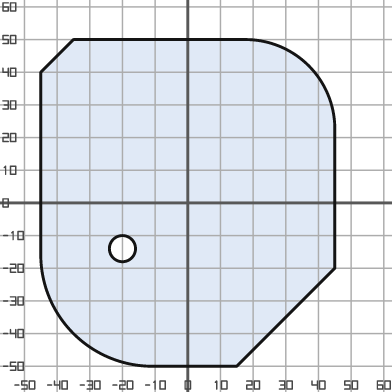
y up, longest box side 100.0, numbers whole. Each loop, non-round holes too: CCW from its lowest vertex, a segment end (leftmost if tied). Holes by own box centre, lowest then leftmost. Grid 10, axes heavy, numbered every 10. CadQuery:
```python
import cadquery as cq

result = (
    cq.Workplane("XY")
    .moveTo(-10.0, -50.0)
    .lineTo(15.0, -50.0)
    .lineTo(45.0, -20.0)
    .lineTo(45.0, 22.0)
    .threePointArc((37.0, 42.0), (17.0, 50.0))
    .lineTo(-35.0, 50.0)
    .lineTo(-45.0, 40.0)
    .lineTo(-45.0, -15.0)
    .threePointArc((-35.0, -40.0), (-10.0, -50.0))
    .close()
    .moveTo(-20.0, -14.0)
    .circle(4.0)
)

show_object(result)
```